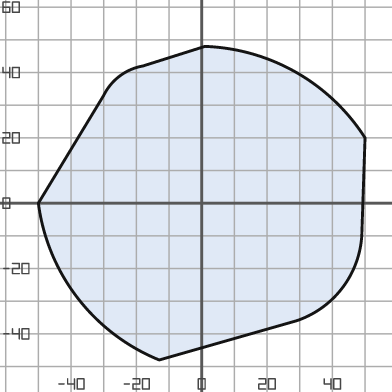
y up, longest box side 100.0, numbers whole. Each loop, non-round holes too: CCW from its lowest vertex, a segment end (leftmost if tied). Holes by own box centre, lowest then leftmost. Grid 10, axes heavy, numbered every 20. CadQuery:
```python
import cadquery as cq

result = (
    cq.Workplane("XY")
    .moveTo(-13.0, -48.0)
    .lineTo(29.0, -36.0)
    .threePointArc((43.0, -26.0), (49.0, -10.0))
    .lineTo(50.0, 20.0)
    .threePointArc((29.0, 40.0), (1.0, 48.0))
    .lineTo(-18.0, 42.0)
    .threePointArc((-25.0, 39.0), (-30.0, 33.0))
    .lineTo(-50.0, 0.0)
    .threePointArc((-38.0, -29.0), (-13.0, -48.0))
    .close()
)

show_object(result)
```